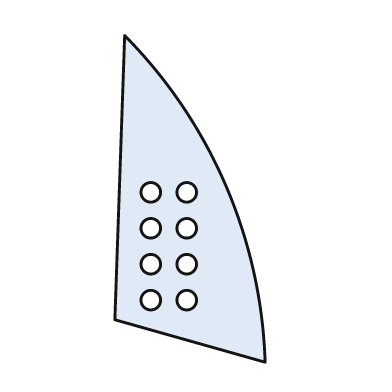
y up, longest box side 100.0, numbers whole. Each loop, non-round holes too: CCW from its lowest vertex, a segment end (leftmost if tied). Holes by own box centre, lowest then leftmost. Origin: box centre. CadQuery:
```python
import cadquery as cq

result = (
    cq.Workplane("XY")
    .moveTo(23.0, -50.0)
    .threePointArc((11.0, 4.0), (-20.0, 50.0))
    .lineTo(-23.0, -37.0)
    .close()
    .moveTo(-12.0, -31.0)
    .circle(3.0)
    .moveTo(-1.0, -31.0)
    .circle(3.0)
    .moveTo(-12.0, -20.0)
    .circle(3.0)
    .moveTo(-1.0, -20.0)
    .circle(3.0)
    .moveTo(-12.0, -9.0)
    .circle(3.0)
    .moveTo(-1.0, -9.0)
    .circle(3.0)
    .moveTo(-12.0, 2.0)
    .circle(3.0)
    .moveTo(-1.0, 2.0)
    .circle(3.0)
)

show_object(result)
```